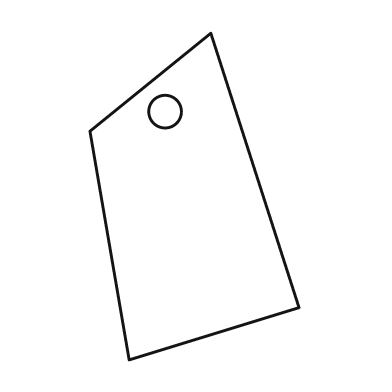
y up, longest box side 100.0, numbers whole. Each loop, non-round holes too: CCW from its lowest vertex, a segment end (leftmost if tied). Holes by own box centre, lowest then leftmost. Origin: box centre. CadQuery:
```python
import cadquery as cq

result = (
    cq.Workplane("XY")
    .moveTo(-20.0, -50.0)
    .lineTo(32.0, -34.0)
    .lineTo(5.0, 50.0)
    .lineTo(-32.0, 20.0)
    .close()
    .moveTo(-9.0, 26.0)
    .circle(5.0)
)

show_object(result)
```